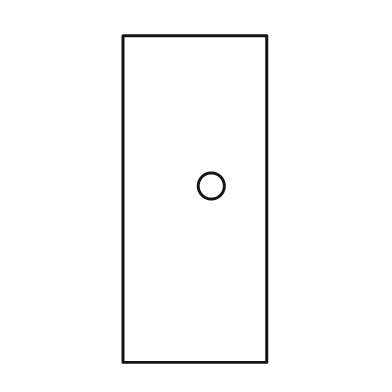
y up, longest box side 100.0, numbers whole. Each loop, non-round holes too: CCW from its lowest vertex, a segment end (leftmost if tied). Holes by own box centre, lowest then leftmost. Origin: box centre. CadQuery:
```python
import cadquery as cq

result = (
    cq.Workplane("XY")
    .moveTo(-22.0, -50.0)
    .lineTo(22.0, -50.0)
    .lineTo(22.0, 50.0)
    .lineTo(-22.0, 50.0)
    .close()
    .moveTo(5.0, 4.0)
    .circle(4.0)
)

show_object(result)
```